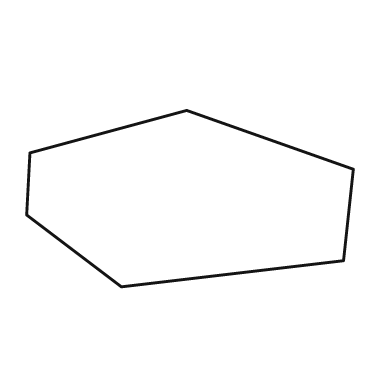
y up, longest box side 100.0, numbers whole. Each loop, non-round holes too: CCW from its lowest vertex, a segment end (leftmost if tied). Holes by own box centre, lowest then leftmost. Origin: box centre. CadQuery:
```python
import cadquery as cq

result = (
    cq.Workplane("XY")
    .moveTo(-21.0, -27.0)
    .lineTo(47.0, -19.0)
    .lineTo(50.0, 9.0)
    .lineTo(-1.0, 27.0)
    .lineTo(-49.0, 14.0)
    .lineTo(-50.0, -5.0)
    .close()
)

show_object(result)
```